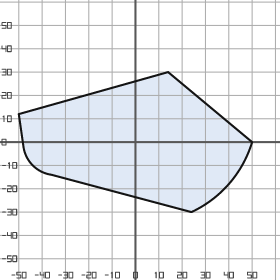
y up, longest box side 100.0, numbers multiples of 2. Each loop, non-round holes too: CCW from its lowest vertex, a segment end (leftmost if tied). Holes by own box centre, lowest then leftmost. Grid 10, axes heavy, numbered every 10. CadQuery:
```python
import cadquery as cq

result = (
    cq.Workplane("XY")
    .moveTo(24.0, -30.0)
    .threePointArc((40.0, -18.0), (50.0, 0.0))
    .lineTo(14.0, 30.0)
    .lineTo(-50.0, 12.0)
    .lineTo(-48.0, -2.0)
    .threePointArc((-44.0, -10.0), (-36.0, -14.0))
    .close()
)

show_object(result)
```